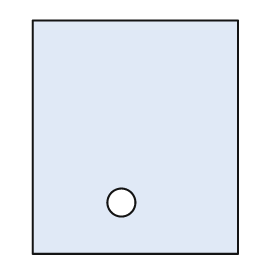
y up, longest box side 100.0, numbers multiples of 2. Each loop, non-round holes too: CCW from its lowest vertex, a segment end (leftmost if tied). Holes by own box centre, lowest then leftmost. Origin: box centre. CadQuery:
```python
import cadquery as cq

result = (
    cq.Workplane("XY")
    .moveTo(-44.0, -50.0)
    .lineTo(44.0, -50.0)
    .lineTo(44.0, 50.0)
    .lineTo(-44.0, 50.0)
    .close()
    .moveTo(-6.0, -28.0)
    .circle(6.0)
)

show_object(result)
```